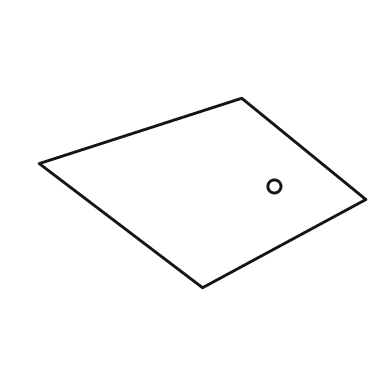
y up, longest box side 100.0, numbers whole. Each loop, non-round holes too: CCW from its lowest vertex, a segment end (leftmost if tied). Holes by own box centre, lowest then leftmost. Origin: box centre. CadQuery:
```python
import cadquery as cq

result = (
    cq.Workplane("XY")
    .moveTo(0.0, -29.0)
    .lineTo(50.0, -2.0)
    .lineTo(12.0, 29.0)
    .lineTo(-50.0, 9.0)
    .close()
    .moveTo(22.0, 2.0)
    .circle(2.0)
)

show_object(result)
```